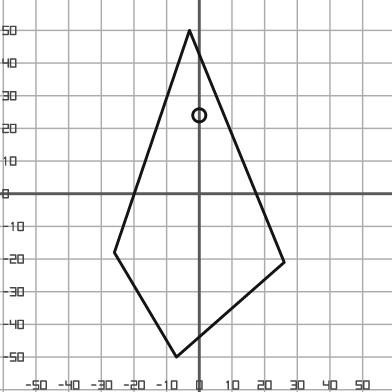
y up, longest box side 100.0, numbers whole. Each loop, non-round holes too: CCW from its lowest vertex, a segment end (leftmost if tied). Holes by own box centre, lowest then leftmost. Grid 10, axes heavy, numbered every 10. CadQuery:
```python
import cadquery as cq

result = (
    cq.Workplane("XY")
    .moveTo(-7.0, -50.0)
    .lineTo(26.0, -21.0)
    .lineTo(-3.0, 50.0)
    .lineTo(-26.0, -18.0)
    .close()
    .moveTo(0.0, 24.0)
    .circle(2.0)
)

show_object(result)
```